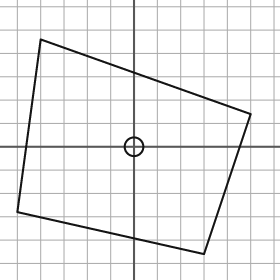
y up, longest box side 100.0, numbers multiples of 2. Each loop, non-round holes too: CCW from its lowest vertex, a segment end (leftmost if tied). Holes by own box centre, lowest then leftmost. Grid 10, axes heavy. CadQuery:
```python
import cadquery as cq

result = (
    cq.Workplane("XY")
    .moveTo(30.0, -46.0)
    .lineTo(50.0, 14.0)
    .lineTo(-40.0, 46.0)
    .lineTo(-50.0, -28.0)
    .close()
    .moveTo(0.0, 0.0)
    .circle(4.0)
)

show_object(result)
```